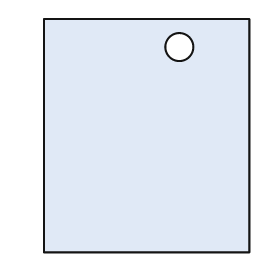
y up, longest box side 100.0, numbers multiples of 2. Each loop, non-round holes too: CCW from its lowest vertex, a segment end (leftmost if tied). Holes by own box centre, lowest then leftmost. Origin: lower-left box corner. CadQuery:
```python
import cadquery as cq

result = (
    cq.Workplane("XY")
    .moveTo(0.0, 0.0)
    .lineTo(88.0, 0.0)
    .lineTo(88.0, 100.0)
    .lineTo(0.0, 100.0)
    .close()
    .moveTo(58.0, 88.0)
    .circle(6.0)
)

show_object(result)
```